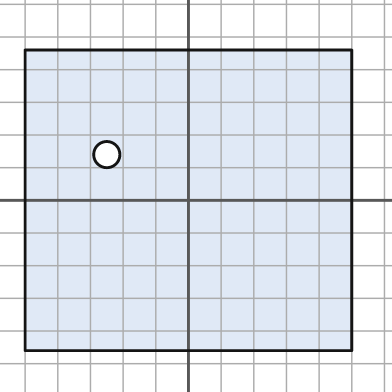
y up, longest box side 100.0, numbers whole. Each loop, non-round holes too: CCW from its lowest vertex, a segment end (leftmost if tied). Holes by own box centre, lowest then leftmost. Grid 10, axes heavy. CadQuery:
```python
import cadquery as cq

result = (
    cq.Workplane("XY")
    .moveTo(-50.0, -46.0)
    .lineTo(50.0, -46.0)
    .lineTo(50.0, 46.0)
    .lineTo(-50.0, 46.0)
    .close()
    .moveTo(-25.0, 14.0)
    .circle(4.0)
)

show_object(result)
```